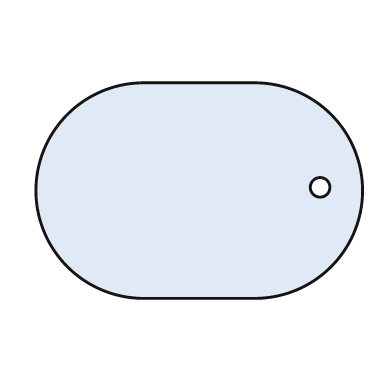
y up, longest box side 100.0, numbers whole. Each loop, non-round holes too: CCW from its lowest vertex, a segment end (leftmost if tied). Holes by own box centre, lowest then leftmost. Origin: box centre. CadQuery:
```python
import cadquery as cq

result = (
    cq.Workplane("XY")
    .moveTo(-17.0, -33.0)
    .lineTo(17.0, -33.0)
    .threePointArc((50.0, 0.0), (17.0, 33.0))
    .lineTo(-17.0, 33.0)
    .threePointArc((-50.0, 0.0), (-17.0, -33.0))
    .close()
    .moveTo(37.0, 1.0)
    .circle(3.0)
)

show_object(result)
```